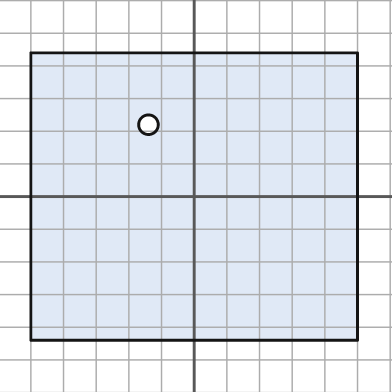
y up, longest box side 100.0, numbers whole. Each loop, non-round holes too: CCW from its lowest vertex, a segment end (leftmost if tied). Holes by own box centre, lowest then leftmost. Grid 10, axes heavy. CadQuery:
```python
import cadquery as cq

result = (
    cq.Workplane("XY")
    .moveTo(-50.0, -44.0)
    .lineTo(50.0, -44.0)
    .lineTo(50.0, 44.0)
    .lineTo(-50.0, 44.0)
    .close()
    .moveTo(-14.0, 22.0)
    .circle(3.0)
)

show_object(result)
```